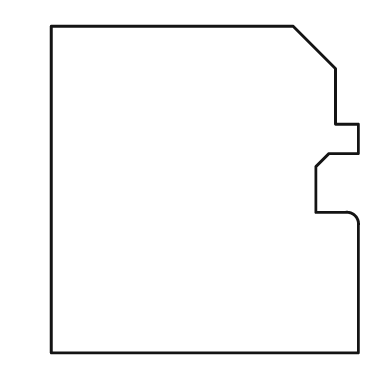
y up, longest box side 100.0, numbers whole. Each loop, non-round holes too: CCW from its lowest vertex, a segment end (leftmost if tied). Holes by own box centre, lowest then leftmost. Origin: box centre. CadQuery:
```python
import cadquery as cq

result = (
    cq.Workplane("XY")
    .moveTo(-47.0, -50.0)
    .lineTo(47.0, -50.0)
    .lineTo(47.0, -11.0)
    .threePointArc((46.0, -8.0), (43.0, -7.0))
    .lineTo(34.0, -7.0)
    .lineTo(34.0, 7.0)
    .lineTo(38.0, 11.0)
    .lineTo(47.0, 11.0)
    .lineTo(47.0, 20.0)
    .lineTo(40.0, 20.0)
    .lineTo(40.0, 37.0)
    .lineTo(27.0, 50.0)
    .lineTo(-47.0, 50.0)
    .close()
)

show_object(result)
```